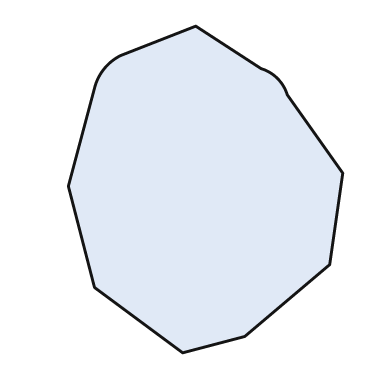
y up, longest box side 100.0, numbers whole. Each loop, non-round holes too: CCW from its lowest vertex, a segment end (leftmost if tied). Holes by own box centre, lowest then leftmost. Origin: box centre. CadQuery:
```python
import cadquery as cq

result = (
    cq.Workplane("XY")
    .moveTo(-7.0, -50.0)
    .lineTo(12.0, -45.0)
    .lineTo(38.0, -23.0)
    .lineTo(42.0, 5.0)
    .lineTo(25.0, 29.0)
    .threePointArc((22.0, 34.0), (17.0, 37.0))
    .lineTo(-3.0, 50.0)
    .lineTo(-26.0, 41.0)
    .threePointArc((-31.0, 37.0), (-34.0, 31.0))
    .lineTo(-42.0, 1.0)
    .lineTo(-34.0, -30.0)
    .close()
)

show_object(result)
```